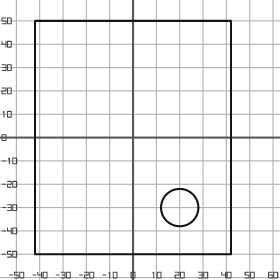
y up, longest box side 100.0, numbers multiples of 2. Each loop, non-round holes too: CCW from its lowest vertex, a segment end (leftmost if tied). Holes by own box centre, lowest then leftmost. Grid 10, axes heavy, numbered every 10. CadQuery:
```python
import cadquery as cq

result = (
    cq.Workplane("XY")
    .moveTo(-42.0, -50.0)
    .lineTo(42.0, -50.0)
    .lineTo(42.0, 50.0)
    .lineTo(-42.0, 50.0)
    .close()
    .moveTo(20.0, -30.0)
    .circle(8.0)
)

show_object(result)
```